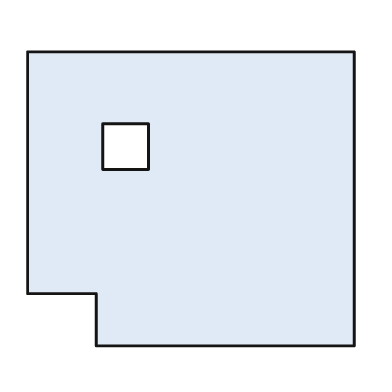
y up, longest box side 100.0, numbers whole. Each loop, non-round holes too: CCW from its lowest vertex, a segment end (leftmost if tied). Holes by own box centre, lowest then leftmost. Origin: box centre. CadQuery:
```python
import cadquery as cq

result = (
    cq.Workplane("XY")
    .moveTo(-29.0, -45.0)
    .lineTo(50.0, -45.0)
    .lineTo(50.0, 45.0)
    .lineTo(-50.0, 45.0)
    .lineTo(-50.0, -29.0)
    .lineTo(-29.0, -29.0)
    .close()
    .moveTo(-27.0, 9.0)
    .lineTo(-13.0, 9.0)
    .lineTo(-13.0, 23.0)
    .lineTo(-27.0, 23.0)
    .close()
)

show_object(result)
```